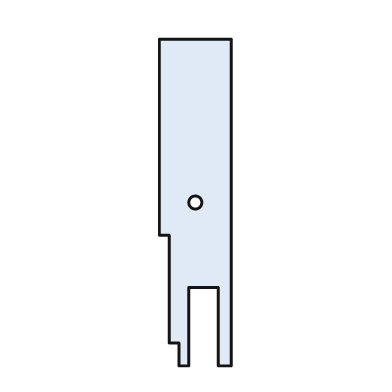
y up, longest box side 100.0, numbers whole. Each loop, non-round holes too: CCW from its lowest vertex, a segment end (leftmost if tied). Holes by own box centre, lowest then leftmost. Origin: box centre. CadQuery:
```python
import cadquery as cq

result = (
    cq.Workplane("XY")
    .moveTo(-5.0, -50.0)
    .lineTo(-2.0, -50.0)
    .lineTo(-2.0, -26.0)
    .lineTo(7.0, -26.0)
    .lineTo(7.0, -50.0)
    .lineTo(11.0, -50.0)
    .lineTo(11.0, 50.0)
    .lineTo(-11.0, 50.0)
    .lineTo(-11.0, -10.0)
    .lineTo(-8.0, -10.0)
    .lineTo(-8.0, -43.0)
    .lineTo(-5.0, -43.0)
    .close()
    .moveTo(0.0, 0.0)
    .circle(2.0)
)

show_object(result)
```